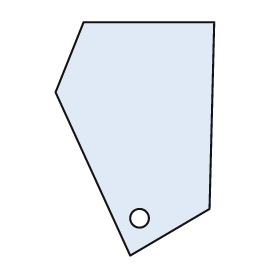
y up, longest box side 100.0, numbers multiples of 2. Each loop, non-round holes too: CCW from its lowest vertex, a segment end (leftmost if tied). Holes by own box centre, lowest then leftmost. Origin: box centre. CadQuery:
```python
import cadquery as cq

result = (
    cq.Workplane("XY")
    .moveTo(-2.0, -50.0)
    .lineTo(32.0, -30.0)
    .lineTo(34.0, 50.0)
    .lineTo(-22.0, 50.0)
    .lineTo(-34.0, 20.0)
    .close()
    .moveTo(2.0, -34.0)
    .circle(4.0)
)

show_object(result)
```